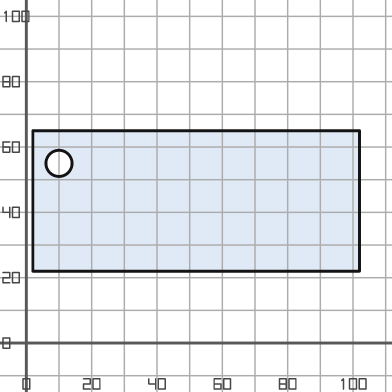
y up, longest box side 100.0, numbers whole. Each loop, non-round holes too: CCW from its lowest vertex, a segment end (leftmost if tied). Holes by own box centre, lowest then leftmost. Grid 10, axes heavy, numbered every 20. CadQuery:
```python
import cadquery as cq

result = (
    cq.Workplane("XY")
    .moveTo(2.0, 22.0)
    .lineTo(102.0, 22.0)
    .lineTo(102.0, 65.0)
    .lineTo(2.0, 65.0)
    .close()
    .moveTo(10.0, 55.0)
    .circle(4.0)
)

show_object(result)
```